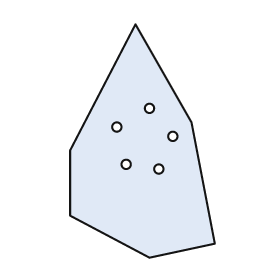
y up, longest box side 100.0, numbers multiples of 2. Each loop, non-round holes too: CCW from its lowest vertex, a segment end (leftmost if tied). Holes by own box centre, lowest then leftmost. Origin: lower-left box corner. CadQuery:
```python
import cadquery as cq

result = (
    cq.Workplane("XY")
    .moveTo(34.0, 0.0)
    .lineTo(62.0, 6.0)
    .lineTo(52.0, 58.0)
    .lineTo(28.0, 100.0)
    .lineTo(0.0, 46.0)
    .lineTo(0.0, 18.0)
    .close()
    .moveTo(38.0, 38.0)
    .circle(2.0)
    .moveTo(24.0, 40.0)
    .circle(2.0)
    .moveTo(44.0, 52.0)
    .circle(2.0)
    .moveTo(20.0, 56.0)
    .circle(2.0)
    .moveTo(34.0, 64.0)
    .circle(2.0)
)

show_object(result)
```